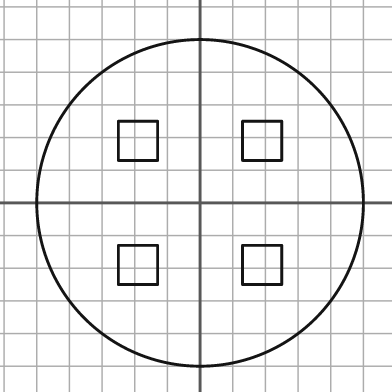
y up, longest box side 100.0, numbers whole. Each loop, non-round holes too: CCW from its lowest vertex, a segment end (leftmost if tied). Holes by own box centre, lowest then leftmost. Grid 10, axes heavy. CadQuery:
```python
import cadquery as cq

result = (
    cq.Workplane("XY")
    .moveTo(0.0, 0.0)
    .circle(50.0)
    .moveTo(-25.0, -25.0)
    .lineTo(-13.0, -25.0)
    .lineTo(-13.0, -13.0)
    .lineTo(-25.0, -13.0)
    .close()
    .moveTo(13.0, -25.0)
    .lineTo(25.0, -25.0)
    .lineTo(25.0, -13.0)
    .lineTo(13.0, -13.0)
    .close()
    .moveTo(-25.0, 13.0)
    .lineTo(-13.0, 13.0)
    .lineTo(-13.0, 25.0)
    .lineTo(-25.0, 25.0)
    .close()
    .moveTo(13.0, 13.0)
    .lineTo(25.0, 13.0)
    .lineTo(25.0, 25.0)
    .lineTo(13.0, 25.0)
    .close()
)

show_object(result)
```